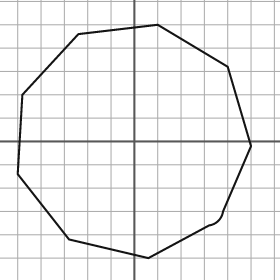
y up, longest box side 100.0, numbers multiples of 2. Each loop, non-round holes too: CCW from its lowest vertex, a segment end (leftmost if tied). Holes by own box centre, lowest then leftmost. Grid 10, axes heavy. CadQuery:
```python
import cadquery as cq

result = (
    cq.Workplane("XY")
    .moveTo(6.0, -50.0)
    .lineTo(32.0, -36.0)
    .threePointArc((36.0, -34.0), (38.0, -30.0))
    .lineTo(50.0, -2.0)
    .lineTo(40.0, 32.0)
    .lineTo(10.0, 50.0)
    .lineTo(-24.0, 46.0)
    .lineTo(-48.0, 20.0)
    .lineTo(-50.0, -14.0)
    .lineTo(-28.0, -42.0)
    .close()
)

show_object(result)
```